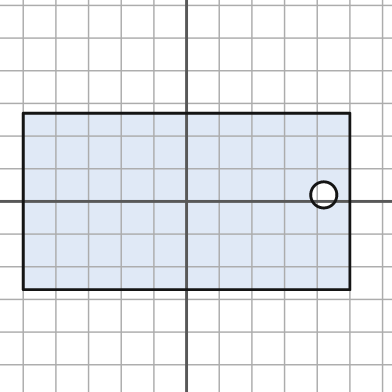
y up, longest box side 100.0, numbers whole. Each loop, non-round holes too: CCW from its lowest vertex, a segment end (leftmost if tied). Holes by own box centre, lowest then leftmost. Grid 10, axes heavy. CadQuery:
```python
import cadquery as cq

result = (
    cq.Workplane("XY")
    .moveTo(-50.0, -27.0)
    .lineTo(50.0, -27.0)
    .lineTo(50.0, 27.0)
    .lineTo(-50.0, 27.0)
    .close()
    .moveTo(42.0, 2.0)
    .circle(4.0)
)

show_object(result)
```